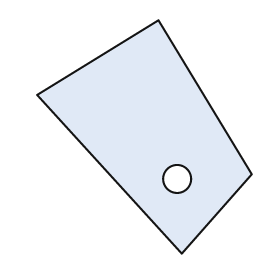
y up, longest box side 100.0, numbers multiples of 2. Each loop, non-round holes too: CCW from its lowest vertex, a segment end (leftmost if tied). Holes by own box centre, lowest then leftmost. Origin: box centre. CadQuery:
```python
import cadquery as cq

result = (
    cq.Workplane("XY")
    .moveTo(16.0, -50.0)
    .lineTo(46.0, -16.0)
    .lineTo(6.0, 50.0)
    .lineTo(-46.0, 18.0)
    .close()
    .moveTo(14.0, -18.0)
    .circle(6.0)
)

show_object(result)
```